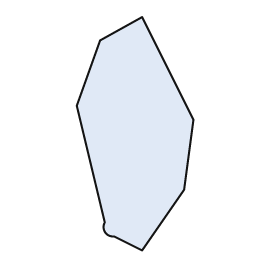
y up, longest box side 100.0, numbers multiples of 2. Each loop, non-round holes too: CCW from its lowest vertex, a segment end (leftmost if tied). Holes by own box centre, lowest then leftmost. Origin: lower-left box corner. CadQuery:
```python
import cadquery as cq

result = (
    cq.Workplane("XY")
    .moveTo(28.0, 0.0)
    .lineTo(46.0, 26.0)
    .lineTo(50.0, 56.0)
    .lineTo(28.0, 100.0)
    .lineTo(10.0, 90.0)
    .lineTo(0.0, 62.0)
    .lineTo(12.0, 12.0)
    .threePointArc((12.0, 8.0), (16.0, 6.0))
    .close()
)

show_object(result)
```